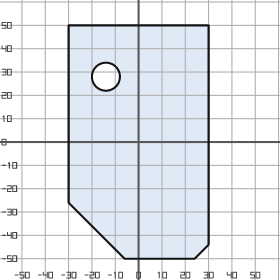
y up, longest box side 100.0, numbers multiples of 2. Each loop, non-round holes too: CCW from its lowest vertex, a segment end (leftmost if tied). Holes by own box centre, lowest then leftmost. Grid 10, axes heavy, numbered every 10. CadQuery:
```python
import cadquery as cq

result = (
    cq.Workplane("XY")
    .moveTo(-6.0, -50.0)
    .lineTo(24.0, -50.0)
    .lineTo(30.0, -44.0)
    .lineTo(30.0, 50.0)
    .lineTo(-30.0, 50.0)
    .lineTo(-30.0, -26.0)
    .close()
    .moveTo(-14.0, 28.0)
    .circle(6.0)
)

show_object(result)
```